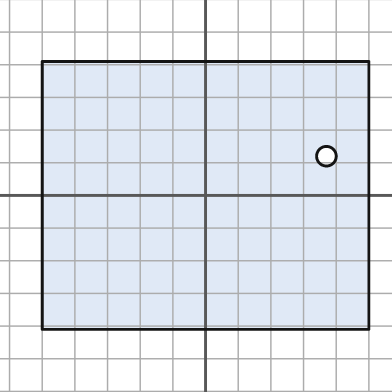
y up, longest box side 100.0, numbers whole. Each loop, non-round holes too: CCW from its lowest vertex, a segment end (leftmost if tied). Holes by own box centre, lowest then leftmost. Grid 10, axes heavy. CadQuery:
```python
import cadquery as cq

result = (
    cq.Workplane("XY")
    .moveTo(-50.0, -41.0)
    .lineTo(50.0, -41.0)
    .lineTo(50.0, 41.0)
    .lineTo(-50.0, 41.0)
    .close()
    .moveTo(37.0, 12.0)
    .circle(3.0)
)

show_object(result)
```